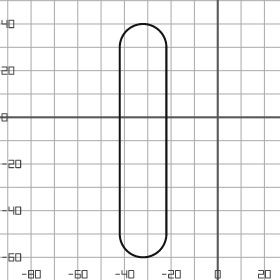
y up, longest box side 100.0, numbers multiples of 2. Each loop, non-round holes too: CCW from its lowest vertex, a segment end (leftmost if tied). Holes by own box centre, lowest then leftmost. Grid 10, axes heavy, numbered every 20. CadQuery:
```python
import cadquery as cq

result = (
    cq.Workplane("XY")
    .moveTo(-42.0, -50.0)
    .threePointArc((-32.0, -60.0), (-22.0, -50.0))
    .lineTo(-22.0, 30.0)
    .threePointArc((-32.0, 40.0), (-42.0, 30.0))
    .close()
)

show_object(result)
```